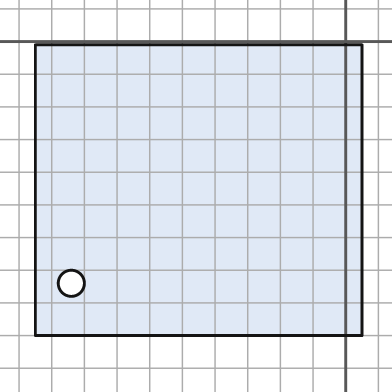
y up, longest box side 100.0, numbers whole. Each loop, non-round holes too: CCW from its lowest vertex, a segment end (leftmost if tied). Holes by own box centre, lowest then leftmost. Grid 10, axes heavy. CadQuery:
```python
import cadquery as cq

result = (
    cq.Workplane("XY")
    .moveTo(-95.0, -90.0)
    .lineTo(5.0, -90.0)
    .lineTo(5.0, -1.0)
    .lineTo(-95.0, -1.0)
    .close()
    .moveTo(-84.0, -74.0)
    .circle(4.0)
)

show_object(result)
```